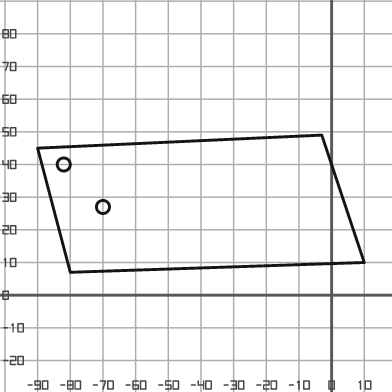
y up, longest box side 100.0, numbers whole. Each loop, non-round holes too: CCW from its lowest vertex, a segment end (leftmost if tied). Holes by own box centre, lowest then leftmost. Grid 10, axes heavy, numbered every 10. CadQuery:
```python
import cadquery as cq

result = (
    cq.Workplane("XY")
    .moveTo(-80.0, 7.0)
    .lineTo(10.0, 10.0)
    .lineTo(-3.0, 49.0)
    .lineTo(-90.0, 45.0)
    .close()
    .moveTo(-70.0, 27.0)
    .circle(2.0)
    .moveTo(-82.0, 40.0)
    .circle(2.0)
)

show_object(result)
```